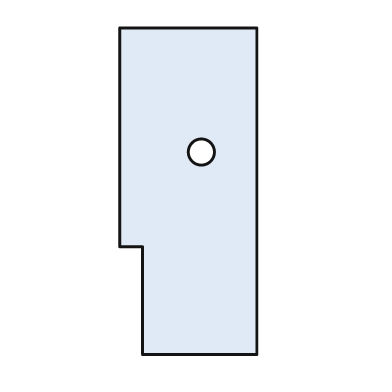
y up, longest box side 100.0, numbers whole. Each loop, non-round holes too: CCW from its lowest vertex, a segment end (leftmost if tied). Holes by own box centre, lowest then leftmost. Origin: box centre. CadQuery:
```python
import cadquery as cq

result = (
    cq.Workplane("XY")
    .moveTo(-14.0, -50.0)
    .lineTo(21.0, -50.0)
    .lineTo(21.0, 50.0)
    .lineTo(-21.0, 50.0)
    .lineTo(-21.0, -17.0)
    .lineTo(-14.0, -17.0)
    .close()
    .moveTo(4.0, 12.0)
    .circle(4.0)
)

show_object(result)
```